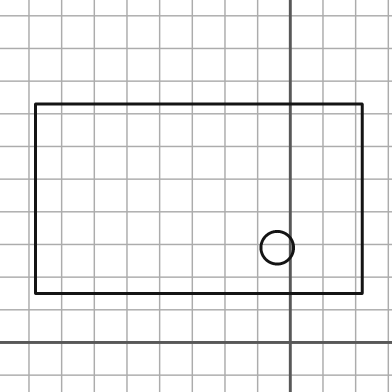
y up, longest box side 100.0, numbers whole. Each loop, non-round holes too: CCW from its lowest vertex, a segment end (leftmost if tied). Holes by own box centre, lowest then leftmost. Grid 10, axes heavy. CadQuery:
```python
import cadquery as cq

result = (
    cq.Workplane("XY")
    .moveTo(-78.0, 15.0)
    .lineTo(22.0, 15.0)
    .lineTo(22.0, 73.0)
    .lineTo(-78.0, 73.0)
    .close()
    .moveTo(-4.0, 29.0)
    .circle(5.0)
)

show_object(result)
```